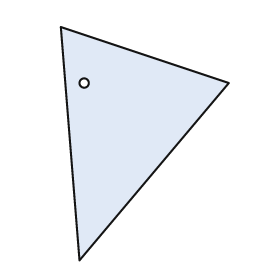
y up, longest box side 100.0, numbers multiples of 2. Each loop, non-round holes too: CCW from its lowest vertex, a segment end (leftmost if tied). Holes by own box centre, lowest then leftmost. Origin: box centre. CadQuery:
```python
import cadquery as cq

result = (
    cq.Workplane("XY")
    .moveTo(-28.0, -50.0)
    .lineTo(36.0, 26.0)
    .lineTo(-36.0, 50.0)
    .close()
    .moveTo(-26.0, 26.0)
    .circle(2.0)
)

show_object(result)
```